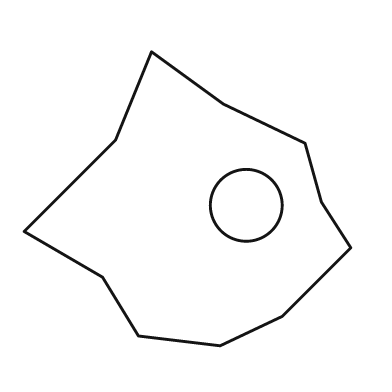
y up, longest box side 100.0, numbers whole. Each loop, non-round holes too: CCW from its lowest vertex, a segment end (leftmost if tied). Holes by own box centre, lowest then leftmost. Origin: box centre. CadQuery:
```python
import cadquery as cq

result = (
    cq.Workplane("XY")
    .moveTo(10.0, -45.0)
    .lineTo(29.0, -36.0)
    .lineTo(50.0, -15.0)
    .lineTo(41.0, -1.0)
    .lineTo(36.0, 17.0)
    .lineTo(11.0, 29.0)
    .lineTo(-11.0, 45.0)
    .lineTo(-22.0, 18.0)
    .lineTo(-50.0, -10.0)
    .lineTo(-26.0, -24.0)
    .lineTo(-15.0, -42.0)
    .close()
    .moveTo(18.0, -2.0)
    .circle(11.0)
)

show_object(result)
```